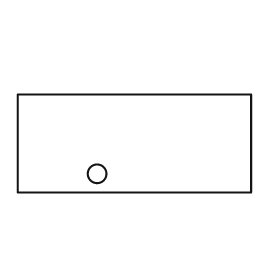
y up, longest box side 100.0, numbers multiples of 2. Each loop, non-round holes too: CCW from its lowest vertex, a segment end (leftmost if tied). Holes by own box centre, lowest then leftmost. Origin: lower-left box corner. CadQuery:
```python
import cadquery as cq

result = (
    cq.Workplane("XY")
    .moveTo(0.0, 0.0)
    .lineTo(100.0, 0.0)
    .lineTo(100.0, 42.0)
    .lineTo(0.0, 42.0)
    .close()
    .moveTo(34.0, 8.0)
    .circle(4.0)
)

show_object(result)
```